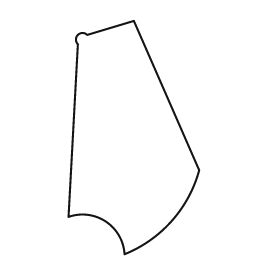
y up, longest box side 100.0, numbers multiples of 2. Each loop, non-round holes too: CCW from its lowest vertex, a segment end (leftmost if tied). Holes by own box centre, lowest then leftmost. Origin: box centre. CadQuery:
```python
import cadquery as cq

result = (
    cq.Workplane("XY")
    .moveTo(-4.0, -50.0)
    .threePointArc((16.0, -36.0), (28.0, -14.0))
    .lineTo(0.0, 50.0)
    .lineTo(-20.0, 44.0)
    .threePointArc((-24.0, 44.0), (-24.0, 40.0))
    .lineTo(-28.0, -34.0)
    .threePointArc((-12.0, -36.0), (-4.0, -50.0))
    .close()
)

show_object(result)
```